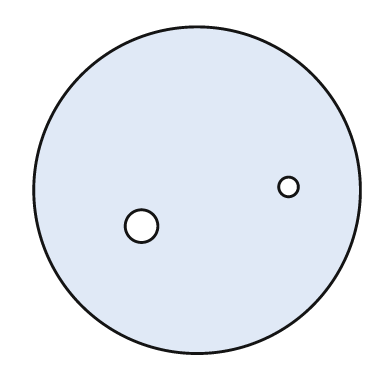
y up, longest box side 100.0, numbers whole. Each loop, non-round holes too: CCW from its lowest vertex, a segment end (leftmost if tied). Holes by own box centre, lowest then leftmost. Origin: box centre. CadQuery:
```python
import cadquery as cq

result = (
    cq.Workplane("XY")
    .moveTo(0.0, 0.0)
    .circle(50.0)
    .moveTo(-17.0, -11.0)
    .circle(5.0)
    .moveTo(28.0, 1.0)
    .circle(3.0)
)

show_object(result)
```